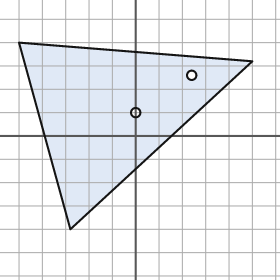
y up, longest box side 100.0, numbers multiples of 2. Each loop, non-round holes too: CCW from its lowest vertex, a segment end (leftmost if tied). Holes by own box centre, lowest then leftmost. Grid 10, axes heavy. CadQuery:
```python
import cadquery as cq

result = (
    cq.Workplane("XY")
    .moveTo(-28.0, -40.0)
    .lineTo(50.0, 32.0)
    .lineTo(-50.0, 40.0)
    .close()
    .moveTo(0.0, 10.0)
    .circle(2.0)
    .moveTo(24.0, 26.0)
    .circle(2.0)
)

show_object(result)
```